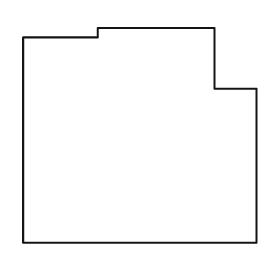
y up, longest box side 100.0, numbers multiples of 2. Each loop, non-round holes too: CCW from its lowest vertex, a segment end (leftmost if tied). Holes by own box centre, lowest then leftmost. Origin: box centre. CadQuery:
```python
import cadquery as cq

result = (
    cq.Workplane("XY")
    .moveTo(-50.0, -46.0)
    .lineTo(50.0, -46.0)
    .lineTo(50.0, 20.0)
    .lineTo(32.0, 20.0)
    .lineTo(32.0, 46.0)
    .lineTo(-18.0, 46.0)
    .lineTo(-18.0, 42.0)
    .lineTo(-50.0, 42.0)
    .close()
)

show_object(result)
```